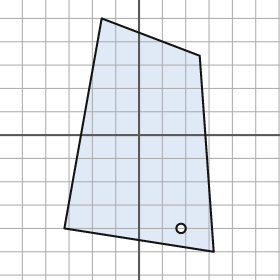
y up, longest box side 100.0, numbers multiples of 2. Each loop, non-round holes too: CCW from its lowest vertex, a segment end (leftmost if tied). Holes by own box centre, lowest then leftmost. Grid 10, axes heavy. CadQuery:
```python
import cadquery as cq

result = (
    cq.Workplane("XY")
    .moveTo(32.0, -50.0)
    .lineTo(26.0, 34.0)
    .lineTo(-16.0, 50.0)
    .lineTo(-32.0, -40.0)
    .close()
    .moveTo(18.0, -40.0)
    .circle(2.0)
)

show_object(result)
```